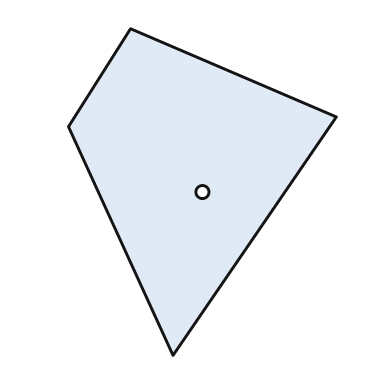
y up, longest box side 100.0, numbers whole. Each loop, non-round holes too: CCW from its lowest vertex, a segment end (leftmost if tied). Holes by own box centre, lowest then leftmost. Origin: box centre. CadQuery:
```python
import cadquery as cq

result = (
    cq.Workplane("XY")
    .moveTo(-9.0, -50.0)
    .lineTo(41.0, 23.0)
    .lineTo(-22.0, 50.0)
    .lineTo(-41.0, 20.0)
    .close()
    .moveTo(0.0, 0.0)
    .circle(2.0)
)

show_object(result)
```